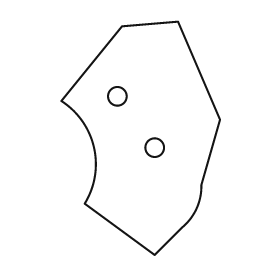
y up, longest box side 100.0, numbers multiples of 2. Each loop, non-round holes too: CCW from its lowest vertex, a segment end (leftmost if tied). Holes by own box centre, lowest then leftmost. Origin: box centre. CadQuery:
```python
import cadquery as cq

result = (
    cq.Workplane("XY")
    .moveTo(6.0, -50.0)
    .lineTo(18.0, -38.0)
    .threePointArc((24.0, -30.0), (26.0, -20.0))
    .lineTo(34.0, 8.0)
    .lineTo(16.0, 50.0)
    .lineTo(-8.0, 48.0)
    .lineTo(-34.0, 16.0)
    .threePointArc((-20.0, -4.0), (-24.0, -28.0))
    .close()
    .moveTo(6.0, -4.0)
    .circle(4.0)
    .moveTo(-10.0, 18.0)
    .circle(4.0)
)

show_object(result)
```